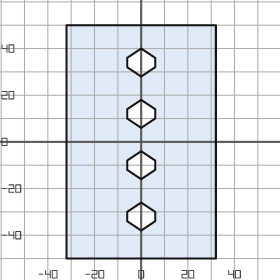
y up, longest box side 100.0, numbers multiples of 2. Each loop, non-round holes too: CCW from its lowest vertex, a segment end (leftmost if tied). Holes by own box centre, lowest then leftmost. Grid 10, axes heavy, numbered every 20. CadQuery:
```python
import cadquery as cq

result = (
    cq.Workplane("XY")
    .moveTo(-32.0, -50.0)
    .lineTo(32.0, -50.0)
    .lineTo(32.0, 50.0)
    .lineTo(-32.0, 50.0)
    .close()
    .moveTo(0.0, -38.0)
    .lineTo(6.0, -34.0)
    .lineTo(6.0, -30.0)
    .lineTo(0.0, -26.0)
    .lineTo(-6.0, -30.0)
    .lineTo(-6.0, -34.0)
    .close()
    .moveTo(0.0, -16.0)
    .lineTo(6.0, -12.0)
    .lineTo(6.0, -8.0)
    .lineTo(0.0, -4.0)
    .lineTo(-6.0, -8.0)
    .lineTo(-6.0, -12.0)
    .close()
    .moveTo(0.0, 6.0)
    .lineTo(6.0, 10.0)
    .lineTo(6.0, 14.0)
    .lineTo(0.0, 18.0)
    .lineTo(-6.0, 14.0)
    .lineTo(-6.0, 10.0)
    .close()
    .moveTo(0.0, 28.0)
    .lineTo(6.0, 32.0)
    .lineTo(6.0, 36.0)
    .lineTo(0.0, 40.0)
    .lineTo(-6.0, 36.0)
    .lineTo(-6.0, 32.0)
    .close()
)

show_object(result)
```